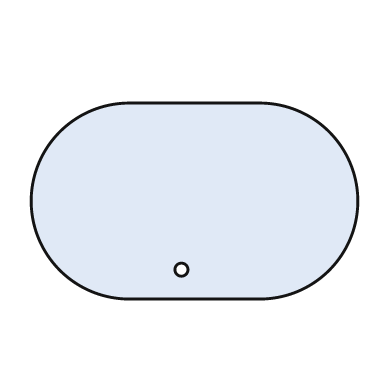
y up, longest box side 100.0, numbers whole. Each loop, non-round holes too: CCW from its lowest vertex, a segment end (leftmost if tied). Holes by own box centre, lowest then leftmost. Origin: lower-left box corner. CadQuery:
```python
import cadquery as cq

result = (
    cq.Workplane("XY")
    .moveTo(30.0, 0.0)
    .lineTo(70.0, 0.0)
    .threePointArc((100.0, 30.0), (70.0, 60.0))
    .lineTo(30.0, 60.0)
    .threePointArc((0.0, 30.0), (30.0, 0.0))
    .close()
    .moveTo(46.0, 9.0)
    .circle(2.0)
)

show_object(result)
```